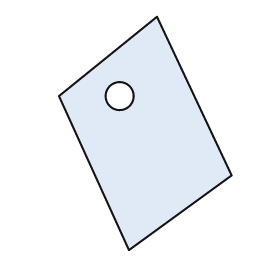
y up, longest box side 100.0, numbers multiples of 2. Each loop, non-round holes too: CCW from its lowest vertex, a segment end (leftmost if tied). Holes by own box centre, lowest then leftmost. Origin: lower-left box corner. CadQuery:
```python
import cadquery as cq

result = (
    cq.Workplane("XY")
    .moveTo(30.0, 0.0)
    .lineTo(74.0, 32.0)
    .lineTo(42.0, 100.0)
    .lineTo(0.0, 66.0)
    .close()
    .moveTo(26.0, 66.0)
    .circle(6.0)
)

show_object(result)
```